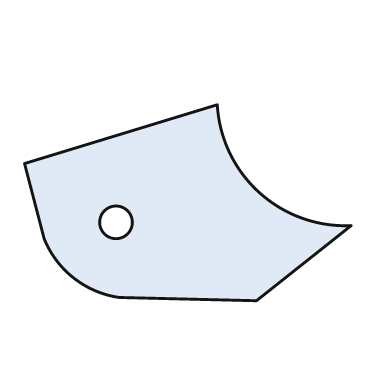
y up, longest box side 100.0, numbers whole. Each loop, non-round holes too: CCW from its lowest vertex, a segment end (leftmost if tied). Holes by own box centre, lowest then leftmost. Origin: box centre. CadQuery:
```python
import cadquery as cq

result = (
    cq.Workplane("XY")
    .moveTo(21.0, -30.0)
    .lineTo(50.0, -7.0)
    .threePointArc((22.0, 3.0), (9.0, 30.0))
    .lineTo(-50.0, 12.0)
    .lineTo(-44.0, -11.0)
    .threePointArc((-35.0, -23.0), (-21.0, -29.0))
    .close()
    .moveTo(-22.0, -6.0)
    .circle(5.0)
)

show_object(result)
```